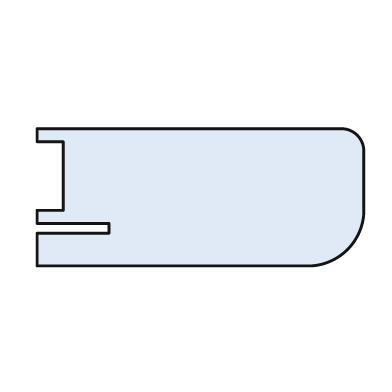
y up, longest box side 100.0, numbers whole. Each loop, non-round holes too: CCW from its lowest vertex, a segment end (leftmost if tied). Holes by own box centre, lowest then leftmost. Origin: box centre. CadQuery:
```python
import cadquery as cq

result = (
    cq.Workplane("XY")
    .moveTo(-50.0, -21.0)
    .lineTo(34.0, -21.0)
    .threePointArc((45.0, -16.0), (50.0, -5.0))
    .lineTo(50.0, 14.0)
    .threePointArc((48.0, 19.0), (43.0, 21.0))
    .lineTo(-50.0, 21.0)
    .lineTo(-50.0, 17.0)
    .lineTo(-42.0, 17.0)
    .lineTo(-42.0, -4.0)
    .lineTo(-50.0, -4.0)
    .lineTo(-50.0, -8.0)
    .lineTo(-28.0, -8.0)
    .lineTo(-28.0, -11.0)
    .lineTo(-50.0, -11.0)
    .close()
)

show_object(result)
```